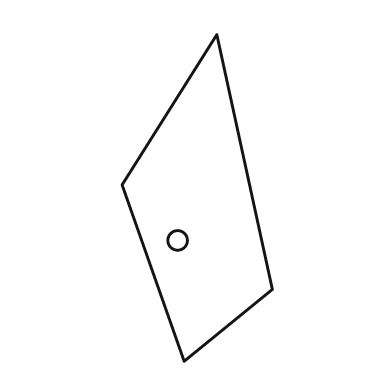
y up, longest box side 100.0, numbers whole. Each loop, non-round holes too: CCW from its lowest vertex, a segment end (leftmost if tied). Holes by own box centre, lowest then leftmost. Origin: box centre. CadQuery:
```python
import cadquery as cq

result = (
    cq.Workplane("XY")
    .moveTo(-4.0, -50.0)
    .lineTo(23.0, -28.0)
    .lineTo(6.0, 50.0)
    .lineTo(-23.0, 4.0)
    .close()
    .moveTo(-6.0, -13.0)
    .circle(3.0)
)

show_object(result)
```